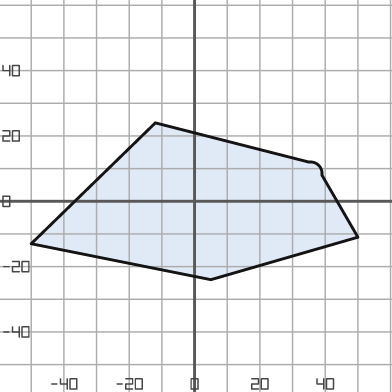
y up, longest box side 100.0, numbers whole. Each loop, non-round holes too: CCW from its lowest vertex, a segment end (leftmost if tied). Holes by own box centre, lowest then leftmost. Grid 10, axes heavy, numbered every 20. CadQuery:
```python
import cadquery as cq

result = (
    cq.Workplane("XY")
    .moveTo(5.0, -24.0)
    .lineTo(50.0, -11.0)
    .lineTo(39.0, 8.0)
    .threePointArc((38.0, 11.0), (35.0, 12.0))
    .lineTo(-12.0, 24.0)
    .lineTo(-50.0, -13.0)
    .close()
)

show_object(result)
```